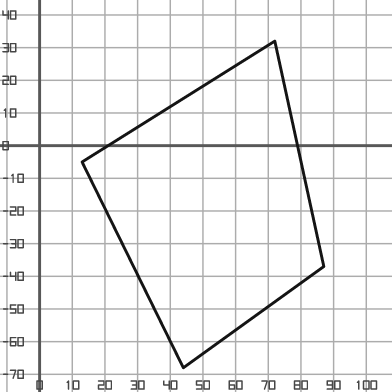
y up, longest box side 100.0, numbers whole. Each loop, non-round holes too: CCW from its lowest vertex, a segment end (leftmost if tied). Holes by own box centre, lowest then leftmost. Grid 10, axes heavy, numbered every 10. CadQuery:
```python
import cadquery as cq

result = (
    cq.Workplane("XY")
    .moveTo(44.0, -68.0)
    .lineTo(87.0, -37.0)
    .lineTo(72.0, 32.0)
    .lineTo(13.0, -5.0)
    .close()
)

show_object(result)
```